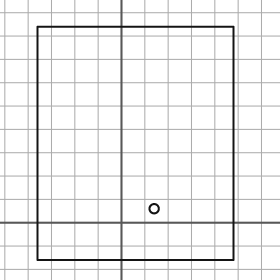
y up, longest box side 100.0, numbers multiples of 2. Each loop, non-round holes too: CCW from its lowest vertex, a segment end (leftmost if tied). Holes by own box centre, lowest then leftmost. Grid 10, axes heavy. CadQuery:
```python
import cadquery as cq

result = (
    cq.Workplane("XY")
    .moveTo(-36.0, -16.0)
    .lineTo(48.0, -16.0)
    .lineTo(48.0, 84.0)
    .lineTo(-36.0, 84.0)
    .close()
    .moveTo(14.0, 6.0)
    .circle(2.0)
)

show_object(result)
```